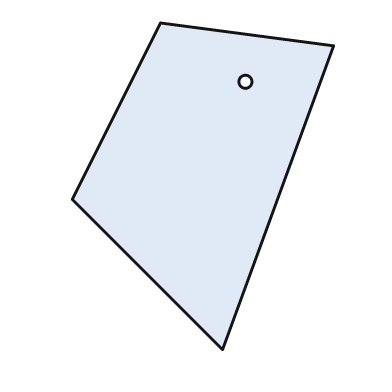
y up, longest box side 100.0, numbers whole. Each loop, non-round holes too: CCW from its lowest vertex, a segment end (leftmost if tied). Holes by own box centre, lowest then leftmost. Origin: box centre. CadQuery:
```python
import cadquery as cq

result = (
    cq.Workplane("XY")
    .moveTo(6.0, -50.0)
    .lineTo(40.0, 43.0)
    .lineTo(-13.0, 50.0)
    .lineTo(-40.0, -4.0)
    .close()
    .moveTo(13.0, 32.0)
    .circle(2.0)
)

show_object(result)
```